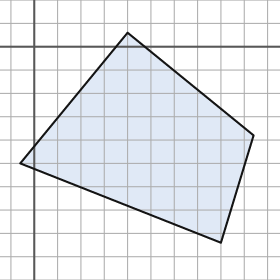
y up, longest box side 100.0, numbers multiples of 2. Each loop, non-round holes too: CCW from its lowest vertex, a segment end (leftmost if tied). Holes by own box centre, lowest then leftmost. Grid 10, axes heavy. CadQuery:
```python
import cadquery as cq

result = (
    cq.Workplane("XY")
    .moveTo(80.0, -84.0)
    .lineTo(94.0, -38.0)
    .lineTo(40.0, 6.0)
    .lineTo(-6.0, -50.0)
    .close()
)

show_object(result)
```